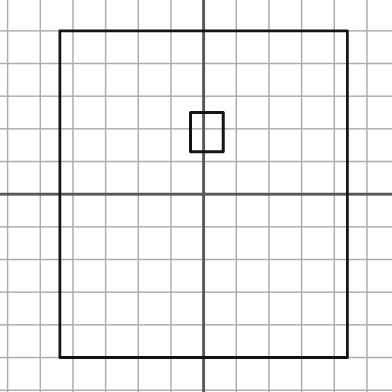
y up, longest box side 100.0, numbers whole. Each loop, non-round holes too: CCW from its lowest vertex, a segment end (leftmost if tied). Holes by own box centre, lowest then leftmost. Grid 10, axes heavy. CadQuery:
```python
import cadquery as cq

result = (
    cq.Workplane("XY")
    .moveTo(-44.0, -50.0)
    .lineTo(44.0, -50.0)
    .lineTo(44.0, 50.0)
    .lineTo(-44.0, 50.0)
    .close()
    .moveTo(-4.0, 13.0)
    .lineTo(6.0, 13.0)
    .lineTo(6.0, 25.0)
    .lineTo(-4.0, 25.0)
    .close()
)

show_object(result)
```